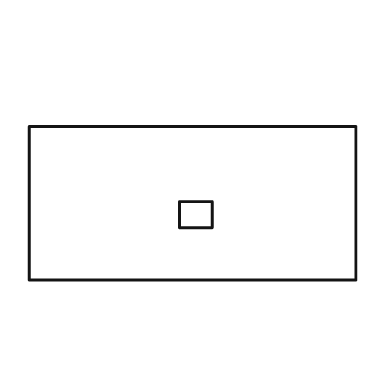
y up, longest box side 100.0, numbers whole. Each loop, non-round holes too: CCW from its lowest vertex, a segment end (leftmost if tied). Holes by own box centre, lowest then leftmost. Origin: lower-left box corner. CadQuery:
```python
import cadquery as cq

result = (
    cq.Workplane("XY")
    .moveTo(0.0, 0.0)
    .lineTo(100.0, 0.0)
    .lineTo(100.0, 47.0)
    .lineTo(0.0, 47.0)
    .close()
    .moveTo(46.0, 16.0)
    .lineTo(56.0, 16.0)
    .lineTo(56.0, 24.0)
    .lineTo(46.0, 24.0)
    .close()
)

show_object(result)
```